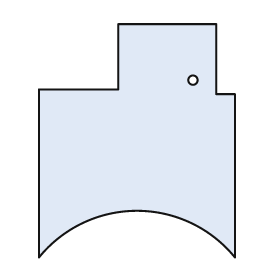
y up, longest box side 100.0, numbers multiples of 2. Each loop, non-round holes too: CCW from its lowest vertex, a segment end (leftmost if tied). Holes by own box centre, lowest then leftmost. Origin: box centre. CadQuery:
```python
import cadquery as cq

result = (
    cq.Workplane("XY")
    .moveTo(-42.0, -50.0)
    .threePointArc((0.0, -30.0), (42.0, -50.0))
    .lineTo(42.0, 20.0)
    .lineTo(34.0, 20.0)
    .lineTo(34.0, 50.0)
    .lineTo(-8.0, 50.0)
    .lineTo(-8.0, 22.0)
    .lineTo(-42.0, 22.0)
    .close()
    .moveTo(24.0, 26.0)
    .circle(2.0)
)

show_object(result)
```